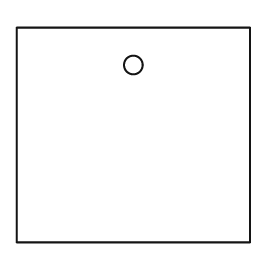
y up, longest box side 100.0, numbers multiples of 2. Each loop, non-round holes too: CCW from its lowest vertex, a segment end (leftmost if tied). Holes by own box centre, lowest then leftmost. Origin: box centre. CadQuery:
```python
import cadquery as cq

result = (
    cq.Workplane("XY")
    .moveTo(-50.0, -46.0)
    .lineTo(50.0, -46.0)
    .lineTo(50.0, 46.0)
    .lineTo(-50.0, 46.0)
    .close()
    .moveTo(0.0, 30.0)
    .circle(4.0)
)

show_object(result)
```